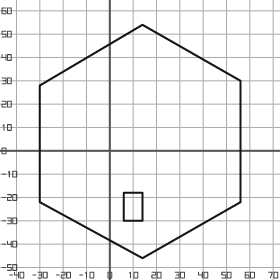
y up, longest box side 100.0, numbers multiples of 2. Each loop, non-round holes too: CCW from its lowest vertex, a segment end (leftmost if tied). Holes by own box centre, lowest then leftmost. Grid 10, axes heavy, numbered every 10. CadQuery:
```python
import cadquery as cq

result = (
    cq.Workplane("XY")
    .moveTo(14.0, -46.0)
    .lineTo(56.0, -22.0)
    .lineTo(56.0, 30.0)
    .lineTo(14.0, 54.0)
    .lineTo(-30.0, 28.0)
    .lineTo(-30.0, -22.0)
    .close()
    .moveTo(6.0, -30.0)
    .lineTo(14.0, -30.0)
    .lineTo(14.0, -18.0)
    .lineTo(6.0, -18.0)
    .close()
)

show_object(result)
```